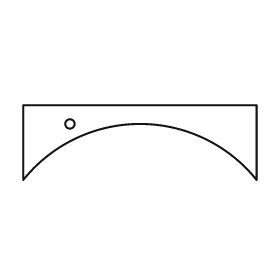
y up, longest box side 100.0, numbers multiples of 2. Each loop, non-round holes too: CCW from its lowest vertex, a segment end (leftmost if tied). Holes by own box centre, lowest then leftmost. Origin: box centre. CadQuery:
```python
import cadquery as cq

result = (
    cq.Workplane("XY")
    .moveTo(-50.0, -16.0)
    .threePointArc((0.0, 8.0), (50.0, -16.0))
    .lineTo(50.0, 16.0)
    .lineTo(-50.0, 16.0)
    .close()
    .moveTo(-30.0, 8.0)
    .circle(2.0)
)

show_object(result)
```